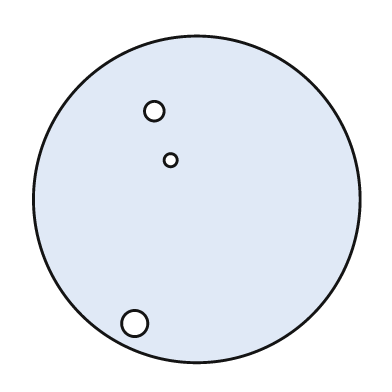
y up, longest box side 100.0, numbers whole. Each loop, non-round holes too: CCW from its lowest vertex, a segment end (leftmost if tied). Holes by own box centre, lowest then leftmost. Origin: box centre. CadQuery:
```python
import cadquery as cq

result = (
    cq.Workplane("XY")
    .moveTo(0.0, 0.0)
    .circle(50.0)
    .moveTo(-19.0, -38.0)
    .circle(4.0)
    .moveTo(-8.0, 12.0)
    .circle(2.0)
    .moveTo(-13.0, 27.0)
    .circle(3.0)
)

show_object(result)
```